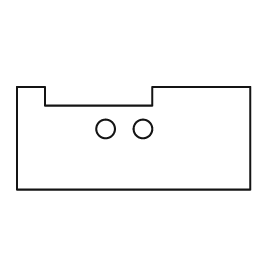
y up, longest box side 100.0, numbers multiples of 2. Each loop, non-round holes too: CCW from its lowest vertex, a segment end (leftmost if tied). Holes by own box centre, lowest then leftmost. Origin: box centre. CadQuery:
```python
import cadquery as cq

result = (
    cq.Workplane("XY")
    .moveTo(-50.0, -22.0)
    .lineTo(50.0, -22.0)
    .lineTo(50.0, 22.0)
    .lineTo(8.0, 22.0)
    .lineTo(8.0, 14.0)
    .lineTo(-38.0, 14.0)
    .lineTo(-38.0, 22.0)
    .lineTo(-50.0, 22.0)
    .close()
    .moveTo(-12.0, 4.0)
    .circle(4.0)
    .moveTo(4.0, 4.0)
    .circle(4.0)
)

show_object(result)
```